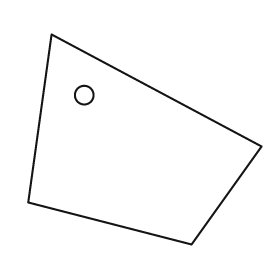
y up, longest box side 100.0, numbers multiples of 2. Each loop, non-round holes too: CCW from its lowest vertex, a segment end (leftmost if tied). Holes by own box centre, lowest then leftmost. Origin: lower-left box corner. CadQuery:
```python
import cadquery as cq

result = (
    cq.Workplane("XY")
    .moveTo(70.0, 0.0)
    .lineTo(100.0, 42.0)
    .lineTo(10.0, 90.0)
    .lineTo(0.0, 18.0)
    .close()
    .moveTo(24.0, 64.0)
    .circle(4.0)
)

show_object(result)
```